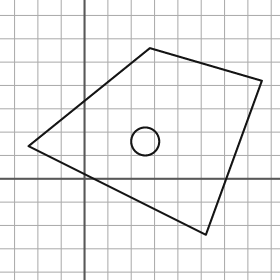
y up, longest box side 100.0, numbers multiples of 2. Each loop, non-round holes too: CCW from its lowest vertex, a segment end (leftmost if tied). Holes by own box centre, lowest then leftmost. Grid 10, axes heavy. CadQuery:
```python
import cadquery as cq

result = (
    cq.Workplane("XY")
    .moveTo(52.0, -24.0)
    .lineTo(76.0, 42.0)
    .lineTo(28.0, 56.0)
    .lineTo(-24.0, 14.0)
    .close()
    .moveTo(26.0, 16.0)
    .circle(6.0)
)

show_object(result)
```